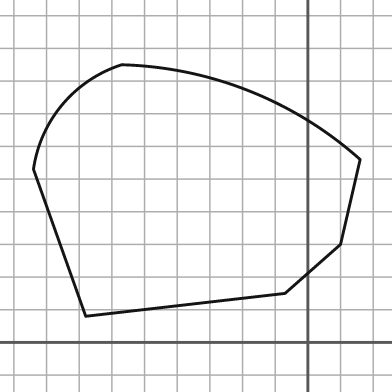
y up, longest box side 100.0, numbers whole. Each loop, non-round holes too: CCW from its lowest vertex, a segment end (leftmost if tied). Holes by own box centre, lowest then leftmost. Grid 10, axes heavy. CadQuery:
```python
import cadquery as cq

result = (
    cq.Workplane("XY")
    .moveTo(-68.0, 8.0)
    .lineTo(-7.0, 15.0)
    .lineTo(10.0, 30.0)
    .lineTo(16.0, 56.0)
    .threePointArc((-18.0, 77.0), (-57.0, 85.0))
    .threePointArc((-75.0, 73.0), (-84.0, 53.0))
    .close()
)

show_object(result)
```